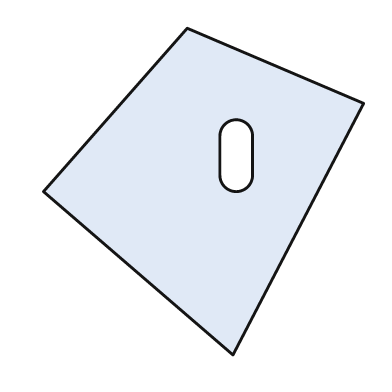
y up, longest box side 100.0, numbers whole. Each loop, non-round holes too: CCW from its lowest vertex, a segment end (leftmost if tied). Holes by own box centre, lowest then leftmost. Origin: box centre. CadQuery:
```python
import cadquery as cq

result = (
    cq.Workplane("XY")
    .moveTo(9.0, -50.0)
    .lineTo(49.0, 27.0)
    .lineTo(-5.0, 50.0)
    .lineTo(-49.0, 0.0)
    .close()
    .moveTo(5.0, 5.0)
    .threePointArc((10.0, 0.0), (15.0, 5.0))
    .lineTo(15.0, 17.0)
    .threePointArc((10.0, 22.0), (5.0, 17.0))
    .close()
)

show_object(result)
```